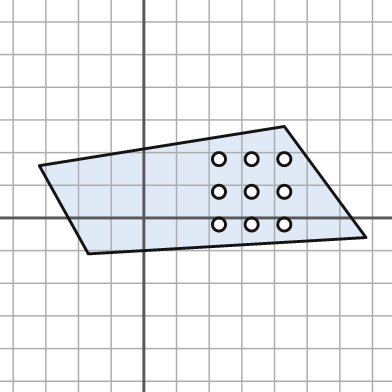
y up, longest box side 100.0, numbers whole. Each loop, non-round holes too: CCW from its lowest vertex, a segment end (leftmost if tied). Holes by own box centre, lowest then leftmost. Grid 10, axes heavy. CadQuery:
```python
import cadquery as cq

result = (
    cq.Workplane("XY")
    .moveTo(-17.0, -11.0)
    .lineTo(68.0, -6.0)
    .lineTo(43.0, 28.0)
    .lineTo(-32.0, 16.0)
    .close()
    .moveTo(23.0, -2.0)
    .circle(2.0)
    .moveTo(33.0, -2.0)
    .circle(2.0)
    .moveTo(43.0, -2.0)
    .circle(2.0)
    .moveTo(23.0, 8.0)
    .circle(2.0)
    .moveTo(33.0, 8.0)
    .circle(2.0)
    .moveTo(43.0, 8.0)
    .circle(2.0)
    .moveTo(23.0, 18.0)
    .circle(2.0)
    .moveTo(33.0, 18.0)
    .circle(2.0)
    .moveTo(43.0, 18.0)
    .circle(2.0)
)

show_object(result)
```